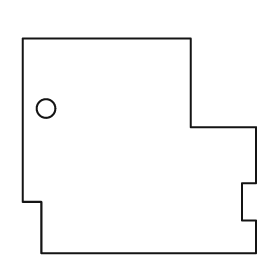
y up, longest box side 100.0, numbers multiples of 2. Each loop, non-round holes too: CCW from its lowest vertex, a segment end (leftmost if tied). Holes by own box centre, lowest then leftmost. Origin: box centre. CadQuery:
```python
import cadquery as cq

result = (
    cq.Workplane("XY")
    .moveTo(-42.0, -46.0)
    .lineTo(50.0, -46.0)
    .lineTo(50.0, -32.0)
    .lineTo(44.0, -32.0)
    .lineTo(44.0, -16.0)
    .lineTo(50.0, -16.0)
    .lineTo(50.0, 8.0)
    .lineTo(22.0, 8.0)
    .lineTo(22.0, 46.0)
    .lineTo(-50.0, 46.0)
    .lineTo(-50.0, -24.0)
    .lineTo(-42.0, -24.0)
    .close()
    .moveTo(-40.0, 16.0)
    .circle(4.0)
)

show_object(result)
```